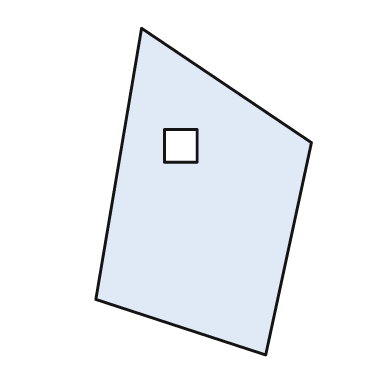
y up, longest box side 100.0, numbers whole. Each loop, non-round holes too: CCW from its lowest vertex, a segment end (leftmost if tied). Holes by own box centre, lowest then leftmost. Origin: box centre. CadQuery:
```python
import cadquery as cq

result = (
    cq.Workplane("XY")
    .moveTo(19.0, -50.0)
    .lineTo(33.0, 15.0)
    .lineTo(-19.0, 50.0)
    .lineTo(-33.0, -33.0)
    .close()
    .moveTo(-12.0, 9.0)
    .lineTo(-2.0, 9.0)
    .lineTo(-2.0, 19.0)
    .lineTo(-12.0, 19.0)
    .close()
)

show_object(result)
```